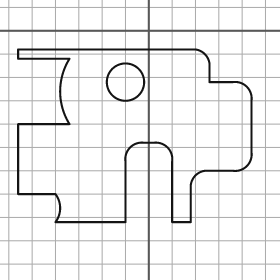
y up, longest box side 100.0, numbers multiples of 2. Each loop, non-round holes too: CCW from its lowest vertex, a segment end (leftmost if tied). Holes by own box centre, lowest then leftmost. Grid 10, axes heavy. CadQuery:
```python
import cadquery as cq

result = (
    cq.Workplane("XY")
    .moveTo(-40.0, -82.0)
    .lineTo(-10.0, -82.0)
    .lineTo(-10.0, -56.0)
    .threePointArc((-8.0, -50.0), (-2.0, -48.0))
    .lineTo(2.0, -48.0)
    .threePointArc((8.0, -50.0), (10.0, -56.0))
    .lineTo(10.0, -82.0)
    .lineTo(18.0, -82.0)
    .lineTo(18.0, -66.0)
    .threePointArc((20.0, -62.0), (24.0, -60.0))
    .lineTo(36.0, -60.0)
    .threePointArc((42.0, -58.0), (44.0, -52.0))
    .lineTo(44.0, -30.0)
    .threePointArc((42.0, -24.0), (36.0, -22.0))
    .lineTo(26.0, -22.0)
    .lineTo(26.0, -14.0)
    .threePointArc((24.0, -10.0), (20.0, -8.0))
    .lineTo(-56.0, -8.0)
    .lineTo(-56.0, -12.0)
    .lineTo(-34.0, -12.0)
    .threePointArc((-38.0, -26.0), (-34.0, -40.0))
    .lineTo(-56.0, -40.0)
    .lineTo(-56.0, -70.0)
    .lineTo(-40.0, -70.0)
    .threePointArc((-38.0, -76.0), (-40.0, -82.0))
    .close()
    .moveTo(-10.0, -22.0)
    .circle(8.0)
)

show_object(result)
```